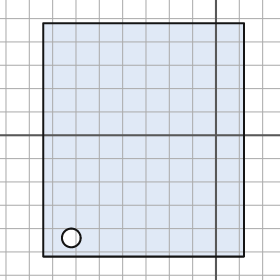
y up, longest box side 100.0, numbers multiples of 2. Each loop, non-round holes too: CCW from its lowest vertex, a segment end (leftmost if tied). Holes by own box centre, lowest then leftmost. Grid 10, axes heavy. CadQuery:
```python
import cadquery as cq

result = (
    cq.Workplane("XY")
    .moveTo(-74.0, -52.0)
    .lineTo(12.0, -52.0)
    .lineTo(12.0, 48.0)
    .lineTo(-74.0, 48.0)
    .close()
    .moveTo(-62.0, -44.0)
    .circle(4.0)
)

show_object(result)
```